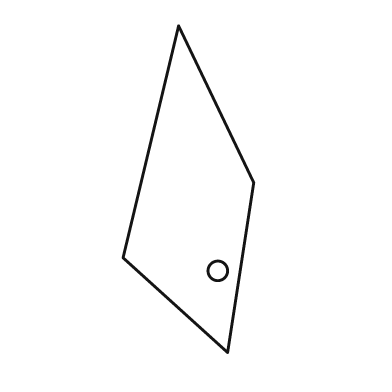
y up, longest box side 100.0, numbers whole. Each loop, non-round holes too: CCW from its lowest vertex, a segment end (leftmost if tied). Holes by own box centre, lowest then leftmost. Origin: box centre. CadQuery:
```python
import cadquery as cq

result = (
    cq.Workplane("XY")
    .moveTo(12.0, -50.0)
    .lineTo(20.0, 2.0)
    .lineTo(-3.0, 50.0)
    .lineTo(-20.0, -21.0)
    .close()
    .moveTo(9.0, -25.0)
    .circle(3.0)
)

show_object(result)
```